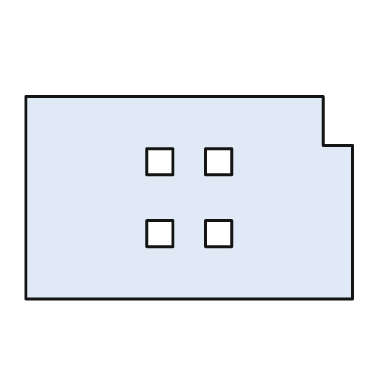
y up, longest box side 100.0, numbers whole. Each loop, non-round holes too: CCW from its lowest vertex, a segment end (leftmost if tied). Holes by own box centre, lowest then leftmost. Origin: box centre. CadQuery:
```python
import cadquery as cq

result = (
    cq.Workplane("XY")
    .moveTo(-50.0, -31.0)
    .lineTo(50.0, -31.0)
    .lineTo(50.0, 16.0)
    .lineTo(41.0, 16.0)
    .lineTo(41.0, 31.0)
    .lineTo(-50.0, 31.0)
    .close()
    .moveTo(-13.0, -15.0)
    .lineTo(-5.0, -15.0)
    .lineTo(-5.0, -7.0)
    .lineTo(-13.0, -7.0)
    .close()
    .moveTo(5.0, -15.0)
    .lineTo(13.0, -15.0)
    .lineTo(13.0, -7.0)
    .lineTo(5.0, -7.0)
    .close()
    .moveTo(-13.0, 7.0)
    .lineTo(-5.0, 7.0)
    .lineTo(-5.0, 15.0)
    .lineTo(-13.0, 15.0)
    .close()
    .moveTo(5.0, 7.0)
    .lineTo(13.0, 7.0)
    .lineTo(13.0, 15.0)
    .lineTo(5.0, 15.0)
    .close()
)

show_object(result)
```